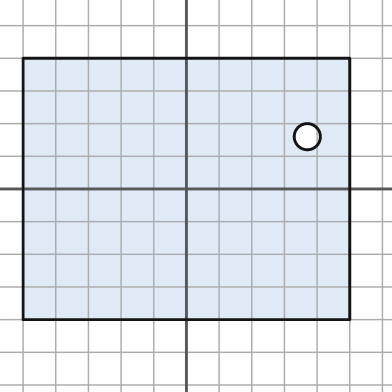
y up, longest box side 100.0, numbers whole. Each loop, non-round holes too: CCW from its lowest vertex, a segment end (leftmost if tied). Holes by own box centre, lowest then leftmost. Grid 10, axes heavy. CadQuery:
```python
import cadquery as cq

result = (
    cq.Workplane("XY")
    .moveTo(-50.0, -40.0)
    .lineTo(50.0, -40.0)
    .lineTo(50.0, 40.0)
    .lineTo(-50.0, 40.0)
    .close()
    .moveTo(37.0, 16.0)
    .circle(4.0)
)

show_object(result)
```